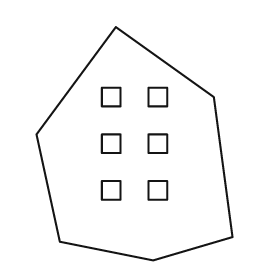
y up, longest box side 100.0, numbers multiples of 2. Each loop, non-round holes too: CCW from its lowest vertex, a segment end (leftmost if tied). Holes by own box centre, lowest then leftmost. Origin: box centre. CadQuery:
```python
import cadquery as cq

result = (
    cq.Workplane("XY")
    .moveTo(8.0, -50.0)
    .lineTo(42.0, -40.0)
    .lineTo(34.0, 20.0)
    .lineTo(-8.0, 50.0)
    .lineTo(-42.0, 4.0)
    .lineTo(-32.0, -42.0)
    .close()
    .moveTo(-14.0, -24.0)
    .lineTo(-6.0, -24.0)
    .lineTo(-6.0, -16.0)
    .lineTo(-14.0, -16.0)
    .close()
    .moveTo(6.0, -24.0)
    .lineTo(14.0, -24.0)
    .lineTo(14.0, -16.0)
    .lineTo(6.0, -16.0)
    .close()
    .moveTo(-14.0, -4.0)
    .lineTo(-6.0, -4.0)
    .lineTo(-6.0, 4.0)
    .lineTo(-14.0, 4.0)
    .close()
    .moveTo(6.0, -4.0)
    .lineTo(14.0, -4.0)
    .lineTo(14.0, 4.0)
    .lineTo(6.0, 4.0)
    .close()
    .moveTo(-14.0, 16.0)
    .lineTo(-6.0, 16.0)
    .lineTo(-6.0, 24.0)
    .lineTo(-14.0, 24.0)
    .close()
    .moveTo(6.0, 16.0)
    .lineTo(14.0, 16.0)
    .lineTo(14.0, 24.0)
    .lineTo(6.0, 24.0)
    .close()
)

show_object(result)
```